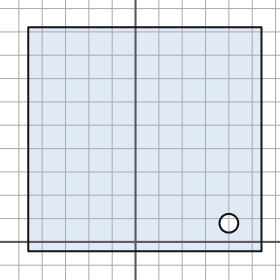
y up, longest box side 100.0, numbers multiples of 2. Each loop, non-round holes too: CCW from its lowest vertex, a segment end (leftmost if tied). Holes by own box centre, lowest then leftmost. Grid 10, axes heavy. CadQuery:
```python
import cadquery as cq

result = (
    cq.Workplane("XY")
    .moveTo(-46.0, -4.0)
    .lineTo(54.0, -4.0)
    .lineTo(54.0, 92.0)
    .lineTo(-46.0, 92.0)
    .close()
    .moveTo(40.0, 8.0)
    .circle(4.0)
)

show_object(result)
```